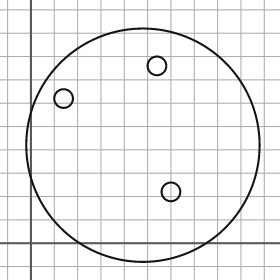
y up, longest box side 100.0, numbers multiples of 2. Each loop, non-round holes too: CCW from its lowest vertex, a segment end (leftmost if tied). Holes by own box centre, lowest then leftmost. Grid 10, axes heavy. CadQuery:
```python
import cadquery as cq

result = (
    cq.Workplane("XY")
    .moveTo(48.0, 42.0)
    .circle(50.0)
    .moveTo(60.0, 22.0)
    .circle(4.0)
    .moveTo(14.0, 62.0)
    .circle(4.0)
    .moveTo(54.0, 76.0)
    .circle(4.0)
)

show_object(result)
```